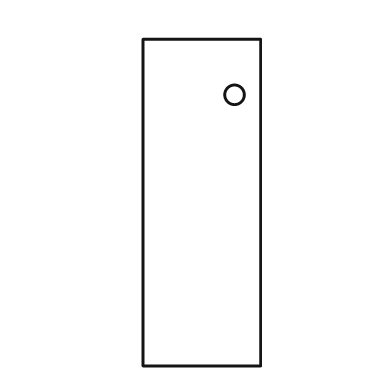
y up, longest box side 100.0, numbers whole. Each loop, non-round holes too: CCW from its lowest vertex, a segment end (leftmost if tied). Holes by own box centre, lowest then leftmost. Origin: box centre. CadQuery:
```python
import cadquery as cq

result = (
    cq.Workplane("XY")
    .moveTo(-18.0, -50.0)
    .lineTo(18.0, -50.0)
    .lineTo(18.0, 50.0)
    .lineTo(-18.0, 50.0)
    .close()
    .moveTo(10.0, 33.0)
    .circle(3.0)
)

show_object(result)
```